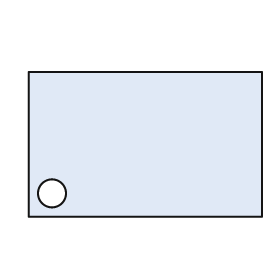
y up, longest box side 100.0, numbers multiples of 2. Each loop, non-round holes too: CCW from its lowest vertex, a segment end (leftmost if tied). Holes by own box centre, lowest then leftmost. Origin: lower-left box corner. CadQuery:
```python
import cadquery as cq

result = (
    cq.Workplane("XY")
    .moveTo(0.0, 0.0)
    .lineTo(100.0, 0.0)
    .lineTo(100.0, 62.0)
    .lineTo(0.0, 62.0)
    .close()
    .moveTo(10.0, 10.0)
    .circle(6.0)
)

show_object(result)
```